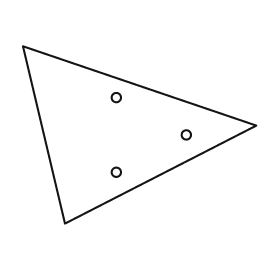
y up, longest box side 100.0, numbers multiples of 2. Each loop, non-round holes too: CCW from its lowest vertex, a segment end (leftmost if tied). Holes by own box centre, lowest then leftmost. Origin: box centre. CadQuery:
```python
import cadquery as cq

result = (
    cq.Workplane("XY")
    .moveTo(-32.0, -38.0)
    .lineTo(50.0, 4.0)
    .lineTo(-50.0, 38.0)
    .close()
    .moveTo(-10.0, -16.0)
    .circle(2.0)
    .moveTo(20.0, 0.0)
    .circle(2.0)
    .moveTo(-10.0, 16.0)
    .circle(2.0)
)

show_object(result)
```